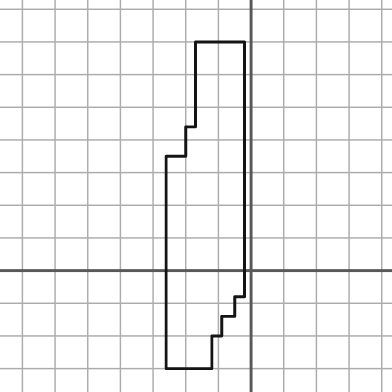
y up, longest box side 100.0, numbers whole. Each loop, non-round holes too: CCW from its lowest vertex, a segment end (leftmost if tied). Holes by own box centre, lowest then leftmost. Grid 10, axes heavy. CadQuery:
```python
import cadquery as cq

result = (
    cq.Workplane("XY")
    .moveTo(-26.0, -30.0)
    .lineTo(-12.0, -30.0)
    .lineTo(-12.0, -20.0)
    .lineTo(-9.0, -20.0)
    .lineTo(-9.0, -14.0)
    .lineTo(-5.0, -14.0)
    .lineTo(-5.0, -8.0)
    .lineTo(-2.0, -8.0)
    .lineTo(-2.0, 70.0)
    .lineTo(-17.0, 70.0)
    .lineTo(-17.0, 44.0)
    .lineTo(-20.0, 44.0)
    .lineTo(-20.0, 35.0)
    .lineTo(-26.0, 35.0)
    .close()
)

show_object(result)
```